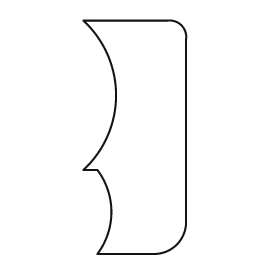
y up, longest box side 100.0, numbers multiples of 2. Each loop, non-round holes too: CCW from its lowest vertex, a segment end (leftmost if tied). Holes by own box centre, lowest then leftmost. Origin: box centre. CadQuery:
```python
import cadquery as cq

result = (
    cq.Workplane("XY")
    .moveTo(-16.0, -50.0)
    .lineTo(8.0, -50.0)
    .threePointArc((18.0, -46.0), (22.0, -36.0))
    .lineTo(22.0, 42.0)
    .threePointArc((20.0, 48.0), (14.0, 50.0))
    .lineTo(-22.0, 50.0)
    .threePointArc((-8.0, 18.0), (-22.0, -14.0))
    .lineTo(-16.0, -14.0)
    .threePointArc((-10.0, -32.0), (-16.0, -50.0))
    .close()
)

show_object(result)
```